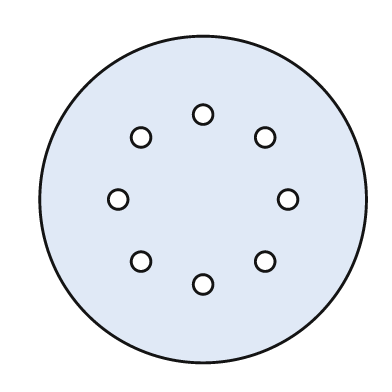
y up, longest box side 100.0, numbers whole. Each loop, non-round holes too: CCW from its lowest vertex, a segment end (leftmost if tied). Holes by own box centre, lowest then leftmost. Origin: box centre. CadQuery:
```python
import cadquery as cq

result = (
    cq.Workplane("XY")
    .moveTo(0.0, 0.0)
    .circle(50.0)
    .moveTo(0.0, -26.0)
    .circle(3.0)
    .moveTo(-19.0, -19.0)
    .circle(3.0)
    .moveTo(19.0, -19.0)
    .circle(3.0)
    .moveTo(-26.0, 0.0)
    .circle(3.0)
    .moveTo(26.0, 0.0)
    .circle(3.0)
    .moveTo(-19.0, 19.0)
    .circle(3.0)
    .moveTo(19.0, 19.0)
    .circle(3.0)
    .moveTo(0.0, 26.0)
    .circle(3.0)
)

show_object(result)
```